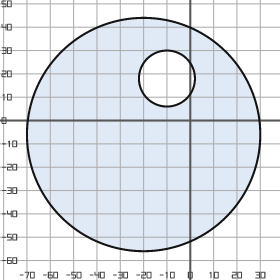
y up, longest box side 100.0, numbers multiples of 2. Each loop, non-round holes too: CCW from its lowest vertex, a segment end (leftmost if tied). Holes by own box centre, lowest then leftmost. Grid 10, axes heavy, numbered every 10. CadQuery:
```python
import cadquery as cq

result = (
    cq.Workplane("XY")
    .moveTo(-20.0, -6.0)
    .circle(50.0)
    .moveTo(-10.0, 18.0)
    .circle(12.0)
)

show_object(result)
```